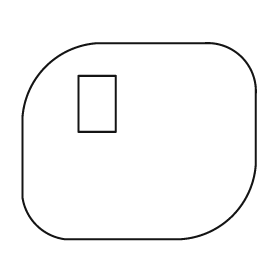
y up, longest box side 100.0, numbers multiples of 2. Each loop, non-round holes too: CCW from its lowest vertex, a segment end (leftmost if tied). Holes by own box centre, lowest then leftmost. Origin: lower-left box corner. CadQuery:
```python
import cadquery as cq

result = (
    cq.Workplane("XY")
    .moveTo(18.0, 0.0)
    .lineTo(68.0, 0.0)
    .threePointArc((90.0, 10.0), (100.0, 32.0))
    .lineTo(100.0, 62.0)
    .threePointArc((94.0, 78.0), (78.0, 84.0))
    .lineTo(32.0, 84.0)
    .threePointArc((10.0, 74.0), (0.0, 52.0))
    .lineTo(0.0, 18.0)
    .threePointArc((6.0, 6.0), (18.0, 0.0))
    .close()
    .moveTo(24.0, 46.0)
    .lineTo(40.0, 46.0)
    .lineTo(40.0, 70.0)
    .lineTo(24.0, 70.0)
    .close()
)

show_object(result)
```